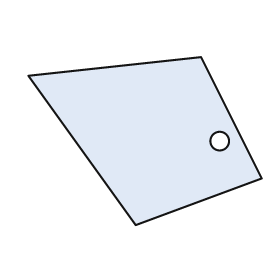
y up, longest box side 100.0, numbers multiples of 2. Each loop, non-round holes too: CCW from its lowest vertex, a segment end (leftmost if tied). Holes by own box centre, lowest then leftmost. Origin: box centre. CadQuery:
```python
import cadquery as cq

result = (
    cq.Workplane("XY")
    .moveTo(-4.0, -36.0)
    .lineTo(50.0, -16.0)
    .lineTo(24.0, 36.0)
    .lineTo(-50.0, 28.0)
    .close()
    .moveTo(32.0, 0.0)
    .circle(4.0)
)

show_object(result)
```